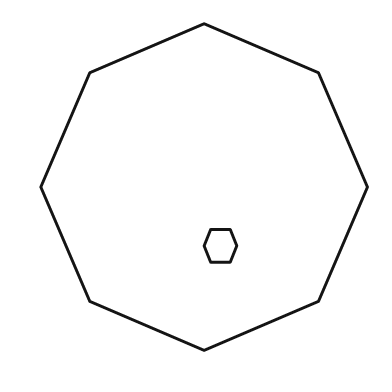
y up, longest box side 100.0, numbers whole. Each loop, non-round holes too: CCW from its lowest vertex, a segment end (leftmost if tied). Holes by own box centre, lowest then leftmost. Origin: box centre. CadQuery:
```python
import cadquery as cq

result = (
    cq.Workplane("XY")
    .moveTo(0.0, -50.0)
    .lineTo(35.0, -35.0)
    .lineTo(50.0, 0.0)
    .lineTo(35.0, 35.0)
    .lineTo(0.0, 50.0)
    .lineTo(-35.0, 35.0)
    .lineTo(-50.0, 0.0)
    .lineTo(-35.0, -35.0)
    .close()
    .moveTo(2.0, -23.0)
    .lineTo(8.0, -23.0)
    .lineTo(10.0, -18.0)
    .lineTo(8.0, -13.0)
    .lineTo(2.0, -13.0)
    .lineTo(0.0, -18.0)
    .close()
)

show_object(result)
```